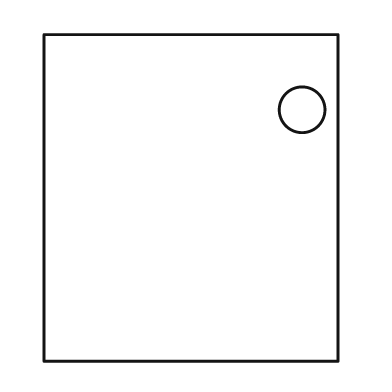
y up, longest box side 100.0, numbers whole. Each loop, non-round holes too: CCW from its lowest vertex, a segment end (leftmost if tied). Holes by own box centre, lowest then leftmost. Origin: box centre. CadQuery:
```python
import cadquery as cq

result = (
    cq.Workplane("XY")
    .moveTo(-45.0, -50.0)
    .lineTo(45.0, -50.0)
    .lineTo(45.0, 50.0)
    .lineTo(-45.0, 50.0)
    .close()
    .moveTo(34.0, 27.0)
    .circle(7.0)
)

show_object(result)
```